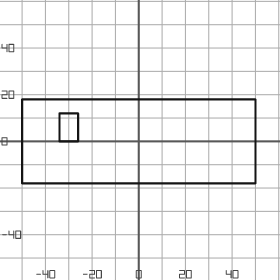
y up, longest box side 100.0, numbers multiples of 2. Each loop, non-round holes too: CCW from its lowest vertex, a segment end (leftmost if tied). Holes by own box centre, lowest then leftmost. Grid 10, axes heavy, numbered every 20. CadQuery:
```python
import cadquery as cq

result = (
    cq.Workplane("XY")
    .moveTo(-50.0, -18.0)
    .lineTo(50.0, -18.0)
    .lineTo(50.0, 18.0)
    .lineTo(-50.0, 18.0)
    .close()
    .moveTo(-34.0, 0.0)
    .lineTo(-26.0, 0.0)
    .lineTo(-26.0, 12.0)
    .lineTo(-34.0, 12.0)
    .close()
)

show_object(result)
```